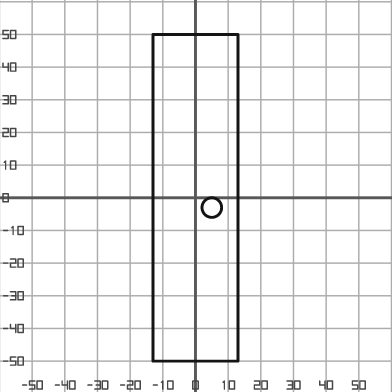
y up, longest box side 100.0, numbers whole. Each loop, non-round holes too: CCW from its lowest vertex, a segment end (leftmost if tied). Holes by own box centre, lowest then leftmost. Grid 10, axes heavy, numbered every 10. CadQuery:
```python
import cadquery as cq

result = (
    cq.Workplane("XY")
    .moveTo(-13.0, -50.0)
    .lineTo(13.0, -50.0)
    .lineTo(13.0, 50.0)
    .lineTo(-13.0, 50.0)
    .close()
    .moveTo(5.0, -3.0)
    .circle(3.0)
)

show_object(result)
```